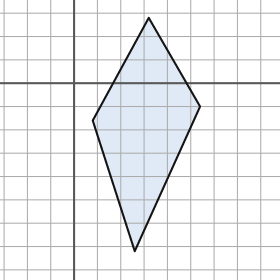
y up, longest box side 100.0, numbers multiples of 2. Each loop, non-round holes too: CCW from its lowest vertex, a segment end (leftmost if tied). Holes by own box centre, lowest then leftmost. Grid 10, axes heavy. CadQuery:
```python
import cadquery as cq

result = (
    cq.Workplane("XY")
    .moveTo(26.0, -72.0)
    .lineTo(54.0, -10.0)
    .lineTo(32.0, 28.0)
    .lineTo(8.0, -16.0)
    .close()
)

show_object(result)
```